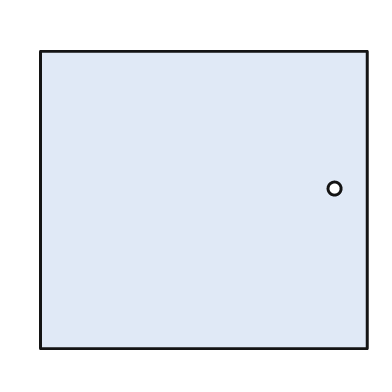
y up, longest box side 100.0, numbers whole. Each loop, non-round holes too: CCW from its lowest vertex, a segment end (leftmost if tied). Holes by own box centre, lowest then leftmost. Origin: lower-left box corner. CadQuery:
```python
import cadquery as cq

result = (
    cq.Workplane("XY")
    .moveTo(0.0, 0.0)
    .lineTo(100.0, 0.0)
    .lineTo(100.0, 91.0)
    .lineTo(0.0, 91.0)
    .close()
    .moveTo(90.0, 49.0)
    .circle(2.0)
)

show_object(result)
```